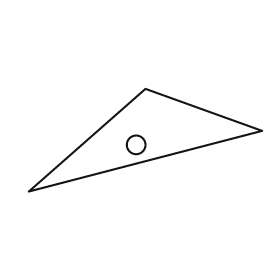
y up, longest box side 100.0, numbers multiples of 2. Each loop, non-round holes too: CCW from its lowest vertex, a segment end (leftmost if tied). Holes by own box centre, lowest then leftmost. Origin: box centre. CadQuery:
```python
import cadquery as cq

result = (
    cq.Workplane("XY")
    .moveTo(-50.0, -22.0)
    .lineTo(50.0, 4.0)
    .lineTo(0.0, 22.0)
    .close()
    .moveTo(-4.0, -2.0)
    .circle(4.0)
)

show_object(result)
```